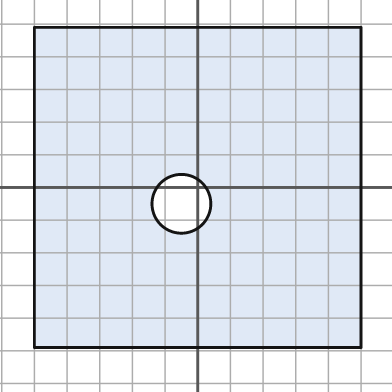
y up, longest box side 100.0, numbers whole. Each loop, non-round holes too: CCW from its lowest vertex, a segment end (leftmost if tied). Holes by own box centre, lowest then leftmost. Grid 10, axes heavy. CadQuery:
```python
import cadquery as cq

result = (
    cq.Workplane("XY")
    .moveTo(-50.0, -49.0)
    .lineTo(50.0, -49.0)
    .lineTo(50.0, 49.0)
    .lineTo(-50.0, 49.0)
    .close()
    .moveTo(-5.0, -5.0)
    .circle(9.0)
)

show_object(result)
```